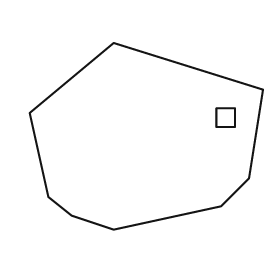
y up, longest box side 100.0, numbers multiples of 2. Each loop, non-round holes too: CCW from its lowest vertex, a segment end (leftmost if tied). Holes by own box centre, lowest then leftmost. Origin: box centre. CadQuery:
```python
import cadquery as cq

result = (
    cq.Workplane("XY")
    .moveTo(-14.0, -40.0)
    .lineTo(32.0, -30.0)
    .lineTo(44.0, -18.0)
    .lineTo(50.0, 20.0)
    .lineTo(-14.0, 40.0)
    .lineTo(-50.0, 10.0)
    .lineTo(-42.0, -26.0)
    .lineTo(-32.0, -34.0)
    .close()
    .moveTo(30.0, 4.0)
    .lineTo(38.0, 4.0)
    .lineTo(38.0, 12.0)
    .lineTo(30.0, 12.0)
    .close()
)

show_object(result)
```